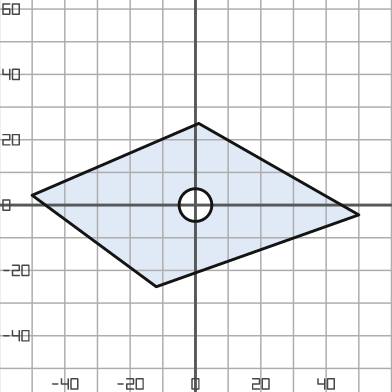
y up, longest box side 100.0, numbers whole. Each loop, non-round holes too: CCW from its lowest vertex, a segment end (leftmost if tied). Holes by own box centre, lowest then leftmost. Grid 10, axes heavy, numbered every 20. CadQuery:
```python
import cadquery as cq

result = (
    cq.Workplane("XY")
    .moveTo(-12.0, -25.0)
    .lineTo(50.0, -3.0)
    .lineTo(1.0, 25.0)
    .lineTo(-50.0, 3.0)
    .close()
    .moveTo(0.0, 0.0)
    .circle(5.0)
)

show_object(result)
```